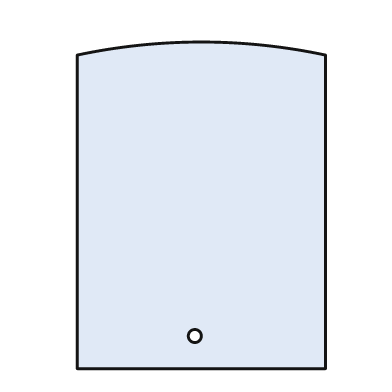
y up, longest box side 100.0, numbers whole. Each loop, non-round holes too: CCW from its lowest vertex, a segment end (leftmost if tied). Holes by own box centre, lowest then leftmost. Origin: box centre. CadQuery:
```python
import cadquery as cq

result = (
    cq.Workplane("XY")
    .moveTo(-38.0, -50.0)
    .lineTo(38.0, -50.0)
    .lineTo(38.0, 46.0)
    .threePointArc((0.0, 50.0), (-38.0, 46.0))
    .close()
    .moveTo(-2.0, -40.0)
    .circle(2.0)
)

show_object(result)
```